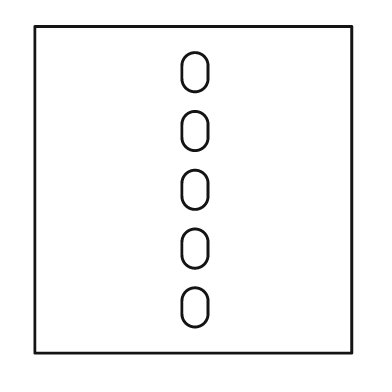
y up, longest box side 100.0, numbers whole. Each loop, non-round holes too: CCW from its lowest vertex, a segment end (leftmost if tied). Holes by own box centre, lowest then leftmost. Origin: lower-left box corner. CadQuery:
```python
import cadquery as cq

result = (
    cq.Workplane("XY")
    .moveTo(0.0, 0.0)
    .lineTo(97.0, 0.0)
    .lineTo(97.0, 100.0)
    .lineTo(0.0, 100.0)
    .close()
    .moveTo(45.0, 12.0)
    .threePointArc((49.0, 8.0), (53.0, 12.0))
    .lineTo(53.0, 16.0)
    .threePointArc((49.0, 20.0), (45.0, 16.0))
    .close()
    .moveTo(45.0, 30.0)
    .threePointArc((49.0, 26.0), (53.0, 30.0))
    .lineTo(53.0, 34.0)
    .threePointArc((49.0, 38.0), (45.0, 34.0))
    .close()
    .moveTo(45.0, 48.0)
    .threePointArc((49.0, 44.0), (53.0, 48.0))
    .lineTo(53.0, 52.0)
    .threePointArc((49.0, 56.0), (45.0, 52.0))
    .close()
    .moveTo(45.0, 66.0)
    .threePointArc((49.0, 62.0), (53.0, 66.0))
    .lineTo(53.0, 70.0)
    .threePointArc((49.0, 74.0), (45.0, 70.0))
    .close()
    .moveTo(45.0, 84.0)
    .threePointArc((49.0, 80.0), (53.0, 84.0))
    .lineTo(53.0, 88.0)
    .threePointArc((49.0, 92.0), (45.0, 88.0))
    .close()
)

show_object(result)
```